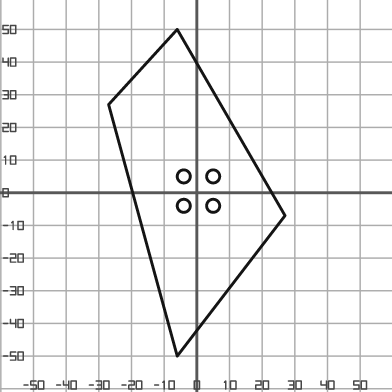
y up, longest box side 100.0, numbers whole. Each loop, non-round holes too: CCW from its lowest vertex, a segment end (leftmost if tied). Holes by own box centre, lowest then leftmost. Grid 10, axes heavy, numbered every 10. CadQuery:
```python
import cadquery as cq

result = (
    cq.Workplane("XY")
    .moveTo(-6.0, -50.0)
    .lineTo(27.0, -7.0)
    .lineTo(-6.0, 50.0)
    .lineTo(-27.0, 27.0)
    .close()
    .moveTo(-4.0, -4.0)
    .circle(2.0)
    .moveTo(5.0, -4.0)
    .circle(2.0)
    .moveTo(-4.0, 5.0)
    .circle(2.0)
    .moveTo(5.0, 5.0)
    .circle(2.0)
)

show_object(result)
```